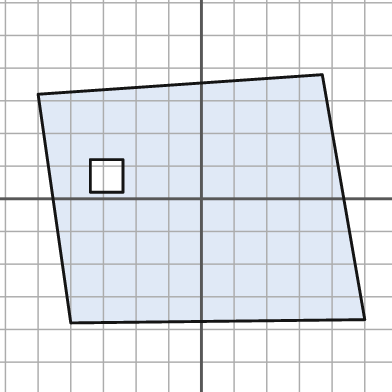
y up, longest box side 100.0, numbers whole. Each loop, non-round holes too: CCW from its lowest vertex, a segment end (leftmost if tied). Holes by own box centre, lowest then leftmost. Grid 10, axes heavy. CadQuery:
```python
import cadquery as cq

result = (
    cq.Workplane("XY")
    .moveTo(-40.0, -38.0)
    .lineTo(50.0, -37.0)
    .lineTo(37.0, 38.0)
    .lineTo(-50.0, 32.0)
    .close()
    .moveTo(-34.0, 2.0)
    .lineTo(-24.0, 2.0)
    .lineTo(-24.0, 12.0)
    .lineTo(-34.0, 12.0)
    .close()
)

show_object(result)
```